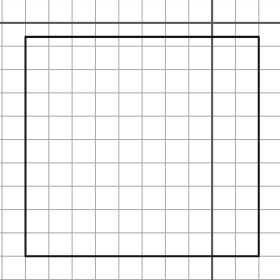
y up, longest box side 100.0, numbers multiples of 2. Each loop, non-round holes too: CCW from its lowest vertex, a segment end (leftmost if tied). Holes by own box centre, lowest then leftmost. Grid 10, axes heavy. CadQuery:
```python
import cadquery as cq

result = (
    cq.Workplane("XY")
    .moveTo(-80.0, -100.0)
    .lineTo(20.0, -100.0)
    .lineTo(20.0, -6.0)
    .lineTo(-80.0, -6.0)
    .close()
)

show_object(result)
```